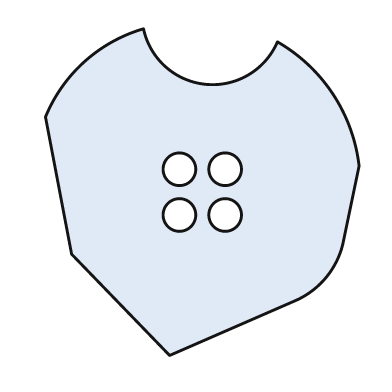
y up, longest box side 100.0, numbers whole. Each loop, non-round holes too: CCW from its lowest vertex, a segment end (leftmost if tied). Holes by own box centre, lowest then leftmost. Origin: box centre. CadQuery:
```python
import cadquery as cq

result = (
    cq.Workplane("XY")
    .moveTo(-10.0, -50.0)
    .lineTo(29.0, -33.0)
    .threePointArc((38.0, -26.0), (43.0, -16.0))
    .lineTo(48.0, 8.0)
    .threePointArc((40.0, 30.0), (23.0, 46.0))
    .threePointArc((1.0, 33.0), (-18.0, 50.0))
    .threePointArc((-36.0, 40.0), (-48.0, 23.0))
    .lineTo(-40.0, -19.0)
    .close()
    .moveTo(-7.0, -7.0)
    .circle(5.0)
    .moveTo(7.0, -7.0)
    .circle(5.0)
    .moveTo(-7.0, 7.0)
    .circle(5.0)
    .moveTo(7.0, 7.0)
    .circle(5.0)
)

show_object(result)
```